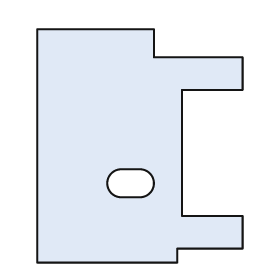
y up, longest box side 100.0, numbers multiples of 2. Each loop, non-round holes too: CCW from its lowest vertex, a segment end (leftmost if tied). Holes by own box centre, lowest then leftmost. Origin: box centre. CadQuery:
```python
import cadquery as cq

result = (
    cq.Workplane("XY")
    .moveTo(-44.0, -50.0)
    .lineTo(16.0, -50.0)
    .lineTo(16.0, -44.0)
    .lineTo(44.0, -44.0)
    .lineTo(44.0, -30.0)
    .lineTo(18.0, -30.0)
    .lineTo(18.0, 24.0)
    .lineTo(44.0, 24.0)
    .lineTo(44.0, 38.0)
    .lineTo(6.0, 38.0)
    .lineTo(6.0, 50.0)
    .lineTo(-44.0, 50.0)
    .close()
    .moveTo(-8.0, -22.0)
    .lineTo(0.0, -22.0)
    .threePointArc((6.0, -16.0), (0.0, -10.0))
    .lineTo(-8.0, -10.0)
    .threePointArc((-14.0, -16.0), (-8.0, -22.0))
    .close()
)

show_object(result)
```